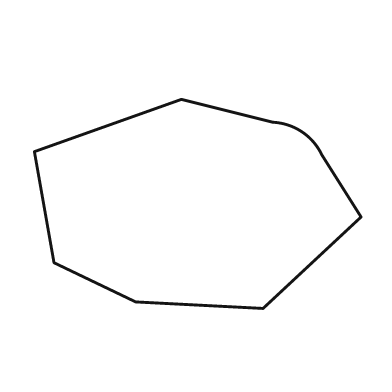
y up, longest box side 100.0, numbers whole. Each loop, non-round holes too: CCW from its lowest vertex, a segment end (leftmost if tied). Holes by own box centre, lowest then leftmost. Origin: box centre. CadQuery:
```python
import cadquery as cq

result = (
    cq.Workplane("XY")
    .moveTo(20.0, -32.0)
    .lineTo(50.0, -4.0)
    .lineTo(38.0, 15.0)
    .threePointArc((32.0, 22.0), (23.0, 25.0))
    .lineTo(-5.0, 32.0)
    .lineTo(-50.0, 16.0)
    .lineTo(-44.0, -18.0)
    .lineTo(-19.0, -30.0)
    .close()
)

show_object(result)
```